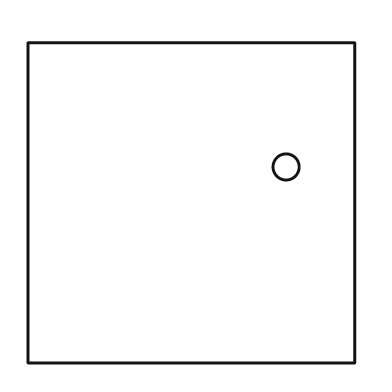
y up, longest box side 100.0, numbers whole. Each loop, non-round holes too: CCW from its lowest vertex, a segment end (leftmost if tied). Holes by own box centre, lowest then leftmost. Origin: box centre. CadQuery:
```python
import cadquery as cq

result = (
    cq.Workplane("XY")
    .moveTo(-50.0, -49.0)
    .lineTo(50.0, -49.0)
    .lineTo(50.0, 49.0)
    .lineTo(-50.0, 49.0)
    .close()
    .moveTo(29.0, 11.0)
    .circle(4.0)
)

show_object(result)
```